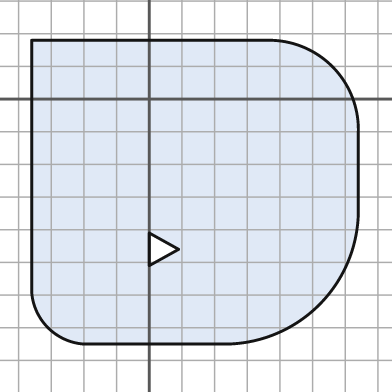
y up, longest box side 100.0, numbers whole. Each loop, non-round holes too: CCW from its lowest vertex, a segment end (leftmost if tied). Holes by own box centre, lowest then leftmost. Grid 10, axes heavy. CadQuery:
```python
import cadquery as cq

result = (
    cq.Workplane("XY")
    .moveTo(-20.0, -75.0)
    .lineTo(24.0, -75.0)
    .threePointArc((52.0, -63.0), (64.0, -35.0))
    .lineTo(64.0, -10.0)
    .threePointArc((56.0, 10.0), (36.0, 18.0))
    .lineTo(-36.0, 18.0)
    .lineTo(-36.0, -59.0)
    .threePointArc((-31.0, -70.0), (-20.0, -75.0))
    .close()
    .moveTo(0.0, -51.0)
    .lineTo(9.0, -46.0)
    .lineTo(0.0, -41.0)
    .close()
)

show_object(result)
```